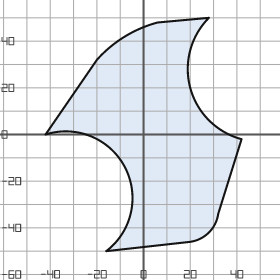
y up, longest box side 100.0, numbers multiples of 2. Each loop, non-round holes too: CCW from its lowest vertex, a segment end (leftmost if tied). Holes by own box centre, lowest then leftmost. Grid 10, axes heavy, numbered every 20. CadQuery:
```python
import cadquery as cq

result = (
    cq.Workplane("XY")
    .moveTo(-16.0, -50.0)
    .lineTo(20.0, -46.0)
    .threePointArc((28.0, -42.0), (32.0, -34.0))
    .lineTo(42.0, -2.0)
    .threePointArc((20.0, 20.0), (28.0, 50.0))
    .lineTo(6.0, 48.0)
    .threePointArc((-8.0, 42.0), (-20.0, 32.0))
    .lineTo(-42.0, 0.0)
    .threePointArc((-8.0, -14.0), (-16.0, -50.0))
    .close()
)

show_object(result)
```